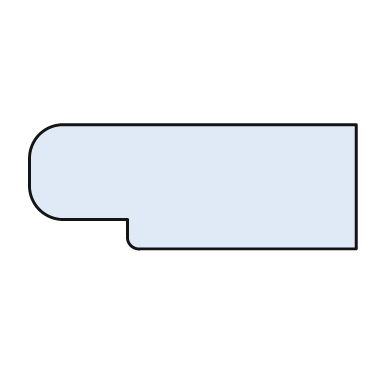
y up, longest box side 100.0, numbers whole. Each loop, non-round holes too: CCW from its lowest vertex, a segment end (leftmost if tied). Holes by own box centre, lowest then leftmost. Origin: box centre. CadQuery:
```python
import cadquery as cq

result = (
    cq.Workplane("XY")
    .moveTo(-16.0, -19.0)
    .lineTo(50.0, -19.0)
    .lineTo(50.0, 19.0)
    .lineTo(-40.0, 19.0)
    .threePointArc((-47.0, 16.0), (-50.0, 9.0))
    .lineTo(-50.0, 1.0)
    .threePointArc((-47.0, -7.0), (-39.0, -10.0))
    .lineTo(-20.0, -10.0)
    .lineTo(-20.0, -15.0)
    .threePointArc((-19.0, -18.0), (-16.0, -19.0))
    .close()
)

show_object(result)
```